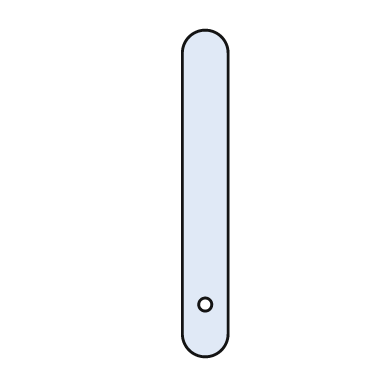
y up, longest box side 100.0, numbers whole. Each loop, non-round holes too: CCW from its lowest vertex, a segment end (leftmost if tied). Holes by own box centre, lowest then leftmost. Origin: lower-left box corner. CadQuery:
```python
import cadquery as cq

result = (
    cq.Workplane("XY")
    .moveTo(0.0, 7.0)
    .threePointArc((7.0, 0.0), (14.0, 7.0))
    .lineTo(14.0, 93.0)
    .threePointArc((7.0, 100.0), (0.0, 93.0))
    .close()
    .moveTo(7.0, 16.0)
    .circle(2.0)
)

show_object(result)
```